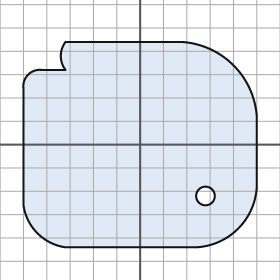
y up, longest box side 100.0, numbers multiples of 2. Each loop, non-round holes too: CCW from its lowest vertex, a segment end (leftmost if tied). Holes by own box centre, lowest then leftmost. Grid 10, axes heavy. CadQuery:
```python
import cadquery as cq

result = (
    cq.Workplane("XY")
    .moveTo(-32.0, -44.0)
    .lineTo(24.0, -44.0)
    .threePointArc((42.0, -36.0), (50.0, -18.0))
    .lineTo(50.0, 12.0)
    .threePointArc((40.0, 34.0), (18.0, 44.0))
    .lineTo(-32.0, 44.0)
    .threePointArc((-34.0, 38.0), (-32.0, 32.0))
    .lineTo(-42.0, 32.0)
    .threePointArc((-48.0, 30.0), (-50.0, 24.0))
    .lineTo(-50.0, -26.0)
    .threePointArc((-44.0, -38.0), (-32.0, -44.0))
    .close()
    .moveTo(28.0, -22.0)
    .circle(4.0)
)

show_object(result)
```